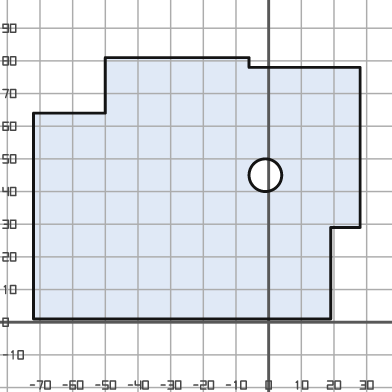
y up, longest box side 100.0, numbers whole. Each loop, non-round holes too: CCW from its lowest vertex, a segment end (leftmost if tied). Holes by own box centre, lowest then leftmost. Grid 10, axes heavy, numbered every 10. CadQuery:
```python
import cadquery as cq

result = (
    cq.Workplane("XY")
    .moveTo(-72.0, 1.0)
    .lineTo(19.0, 1.0)
    .lineTo(19.0, 29.0)
    .lineTo(28.0, 29.0)
    .lineTo(28.0, 78.0)
    .lineTo(-6.0, 78.0)
    .lineTo(-6.0, 81.0)
    .lineTo(-50.0, 81.0)
    .lineTo(-50.0, 64.0)
    .lineTo(-72.0, 64.0)
    .close()
    .moveTo(-1.0, 45.0)
    .circle(5.0)
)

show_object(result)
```